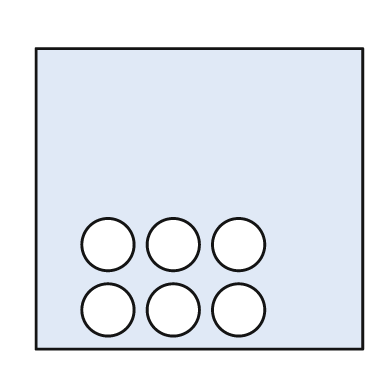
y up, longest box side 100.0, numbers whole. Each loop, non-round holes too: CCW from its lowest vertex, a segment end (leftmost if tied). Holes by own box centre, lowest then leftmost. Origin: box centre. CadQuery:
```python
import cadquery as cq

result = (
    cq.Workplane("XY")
    .moveTo(-50.0, -46.0)
    .lineTo(50.0, -46.0)
    .lineTo(50.0, 46.0)
    .lineTo(-50.0, 46.0)
    .close()
    .moveTo(-28.0, -34.0)
    .circle(8.0)
    .moveTo(-8.0, -34.0)
    .circle(8.0)
    .moveTo(12.0, -34.0)
    .circle(8.0)
    .moveTo(-28.0, -14.0)
    .circle(8.0)
    .moveTo(-8.0, -14.0)
    .circle(8.0)
    .moveTo(12.0, -14.0)
    .circle(8.0)
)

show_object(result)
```